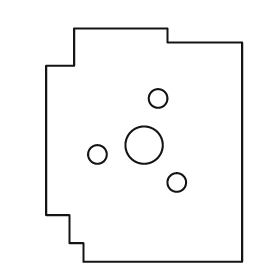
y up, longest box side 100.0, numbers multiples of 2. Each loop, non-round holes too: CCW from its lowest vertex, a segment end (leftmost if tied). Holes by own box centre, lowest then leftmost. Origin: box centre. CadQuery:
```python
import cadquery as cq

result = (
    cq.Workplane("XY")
    .moveTo(-26.0, -50.0)
    .lineTo(42.0, -50.0)
    .lineTo(42.0, 44.0)
    .lineTo(10.0, 44.0)
    .lineTo(10.0, 50.0)
    .lineTo(-30.0, 50.0)
    .lineTo(-30.0, 34.0)
    .lineTo(-42.0, 34.0)
    .lineTo(-42.0, -30.0)
    .lineTo(-32.0, -30.0)
    .lineTo(-32.0, -42.0)
    .lineTo(-26.0, -42.0)
    .close()
    .moveTo(14.0, -16.0)
    .circle(4.0)
    .moveTo(-20.0, -4.0)
    .circle(4.0)
    .moveTo(0.0, 0.0)
    .circle(8.0)
    .moveTo(6.0, 20.0)
    .circle(4.0)
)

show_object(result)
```